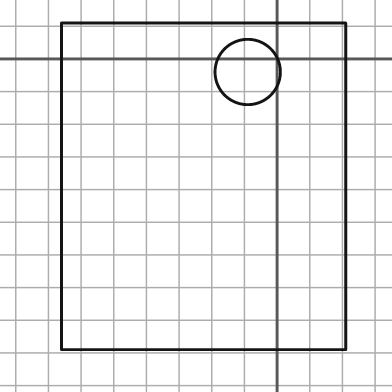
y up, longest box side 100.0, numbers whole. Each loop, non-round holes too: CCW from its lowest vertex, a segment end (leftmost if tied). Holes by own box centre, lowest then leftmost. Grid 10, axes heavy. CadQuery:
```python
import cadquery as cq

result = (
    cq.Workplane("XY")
    .moveTo(-66.0, -89.0)
    .lineTo(21.0, -89.0)
    .lineTo(21.0, 11.0)
    .lineTo(-66.0, 11.0)
    .close()
    .moveTo(-9.0, -4.0)
    .circle(10.0)
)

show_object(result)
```